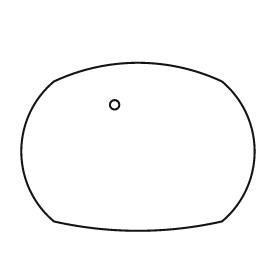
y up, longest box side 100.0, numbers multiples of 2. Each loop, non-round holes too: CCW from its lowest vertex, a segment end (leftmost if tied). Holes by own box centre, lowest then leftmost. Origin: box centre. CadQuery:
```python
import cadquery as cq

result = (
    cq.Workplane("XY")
    .moveTo(-36.0, -32.0)
    .threePointArc((0.0, -36.0), (36.0, -32.0))
    .threePointArc((50.0, -2.0), (36.0, 28.0))
    .threePointArc((0.0, 36.0), (-36.0, 28.0))
    .threePointArc((-50.0, -2.0), (-36.0, -32.0))
    .close()
    .moveTo(-10.0, 18.0)
    .circle(2.0)
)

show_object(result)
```